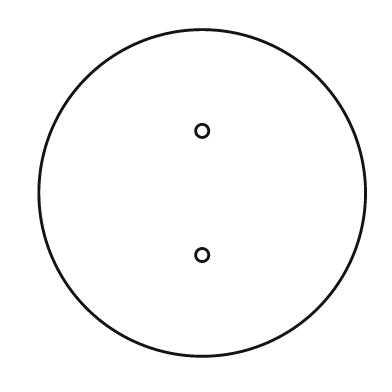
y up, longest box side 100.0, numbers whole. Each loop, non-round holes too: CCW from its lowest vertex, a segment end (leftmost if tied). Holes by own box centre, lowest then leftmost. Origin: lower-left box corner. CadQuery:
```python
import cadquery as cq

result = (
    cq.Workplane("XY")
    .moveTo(50.0, 50.0)
    .circle(50.0)
    .moveTo(50.0, 31.0)
    .circle(2.0)
    .moveTo(50.0, 69.0)
    .circle(2.0)
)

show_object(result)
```